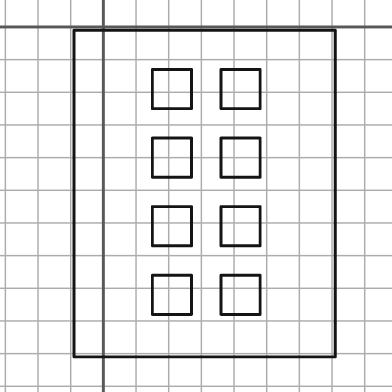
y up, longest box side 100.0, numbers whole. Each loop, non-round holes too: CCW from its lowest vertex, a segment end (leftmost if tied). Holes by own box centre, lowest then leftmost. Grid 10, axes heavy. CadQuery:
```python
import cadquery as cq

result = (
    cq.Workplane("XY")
    .moveTo(-9.0, -101.0)
    .lineTo(71.0, -101.0)
    .lineTo(71.0, -1.0)
    .lineTo(-9.0, -1.0)
    .close()
    .moveTo(15.0, -88.0)
    .lineTo(27.0, -88.0)
    .lineTo(27.0, -76.0)
    .lineTo(15.0, -76.0)
    .close()
    .moveTo(36.0, -88.0)
    .lineTo(48.0, -88.0)
    .lineTo(48.0, -76.0)
    .lineTo(36.0, -76.0)
    .close()
    .moveTo(15.0, -67.0)
    .lineTo(27.0, -67.0)
    .lineTo(27.0, -55.0)
    .lineTo(15.0, -55.0)
    .close()
    .moveTo(36.0, -67.0)
    .lineTo(48.0, -67.0)
    .lineTo(48.0, -55.0)
    .lineTo(36.0, -55.0)
    .close()
    .moveTo(15.0, -46.0)
    .lineTo(27.0, -46.0)
    .lineTo(27.0, -34.0)
    .lineTo(15.0, -34.0)
    .close()
    .moveTo(36.0, -46.0)
    .lineTo(48.0, -46.0)
    .lineTo(48.0, -34.0)
    .lineTo(36.0, -34.0)
    .close()
    .moveTo(15.0, -25.0)
    .lineTo(27.0, -25.0)
    .lineTo(27.0, -13.0)
    .lineTo(15.0, -13.0)
    .close()
    .moveTo(36.0, -25.0)
    .lineTo(48.0, -25.0)
    .lineTo(48.0, -13.0)
    .lineTo(36.0, -13.0)
    .close()
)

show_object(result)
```